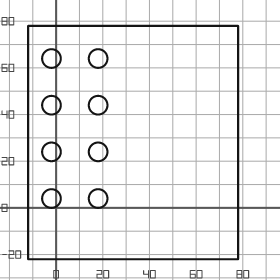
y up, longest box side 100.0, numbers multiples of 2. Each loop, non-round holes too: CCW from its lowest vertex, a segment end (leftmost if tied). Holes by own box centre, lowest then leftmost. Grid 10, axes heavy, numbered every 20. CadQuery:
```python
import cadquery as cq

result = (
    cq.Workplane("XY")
    .moveTo(-12.0, -22.0)
    .lineTo(78.0, -22.0)
    .lineTo(78.0, 78.0)
    .lineTo(-12.0, 78.0)
    .close()
    .moveTo(-2.0, 4.0)
    .circle(4.0)
    .moveTo(18.0, 4.0)
    .circle(4.0)
    .moveTo(-2.0, 24.0)
    .circle(4.0)
    .moveTo(18.0, 24.0)
    .circle(4.0)
    .moveTo(-2.0, 44.0)
    .circle(4.0)
    .moveTo(18.0, 44.0)
    .circle(4.0)
    .moveTo(-2.0, 64.0)
    .circle(4.0)
    .moveTo(18.0, 64.0)
    .circle(4.0)
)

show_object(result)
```